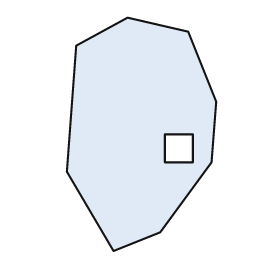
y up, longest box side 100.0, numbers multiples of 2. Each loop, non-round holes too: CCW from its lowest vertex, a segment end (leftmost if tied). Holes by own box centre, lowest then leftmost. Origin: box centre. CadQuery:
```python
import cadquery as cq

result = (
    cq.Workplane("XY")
    .moveTo(-12.0, -50.0)
    .lineTo(8.0, -42.0)
    .lineTo(30.0, -12.0)
    .lineTo(32.0, 14.0)
    .lineTo(20.0, 44.0)
    .lineTo(-6.0, 50.0)
    .lineTo(-28.0, 38.0)
    .lineTo(-32.0, -16.0)
    .close()
    .moveTo(10.0, -12.0)
    .lineTo(22.0, -12.0)
    .lineTo(22.0, 0.0)
    .lineTo(10.0, 0.0)
    .close()
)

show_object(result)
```